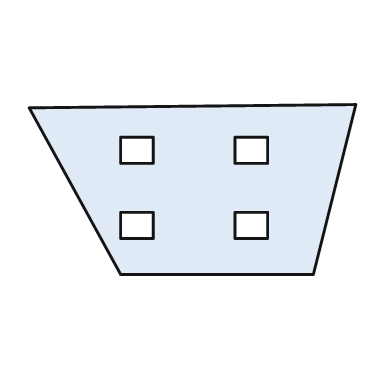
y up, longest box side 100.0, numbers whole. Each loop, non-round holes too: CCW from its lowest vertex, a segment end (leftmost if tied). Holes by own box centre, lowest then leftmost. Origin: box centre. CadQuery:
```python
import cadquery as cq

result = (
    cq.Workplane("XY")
    .moveTo(-22.0, -26.0)
    .lineTo(37.0, -26.0)
    .lineTo(50.0, 26.0)
    .lineTo(-50.0, 25.0)
    .close()
    .moveTo(-22.0, -15.0)
    .lineTo(-12.0, -15.0)
    .lineTo(-12.0, -7.0)
    .lineTo(-22.0, -7.0)
    .close()
    .moveTo(13.0, -15.0)
    .lineTo(23.0, -15.0)
    .lineTo(23.0, -7.0)
    .lineTo(13.0, -7.0)
    .close()
    .moveTo(-22.0, 8.0)
    .lineTo(-12.0, 8.0)
    .lineTo(-12.0, 16.0)
    .lineTo(-22.0, 16.0)
    .close()
    .moveTo(13.0, 8.0)
    .lineTo(23.0, 8.0)
    .lineTo(23.0, 16.0)
    .lineTo(13.0, 16.0)
    .close()
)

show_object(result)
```